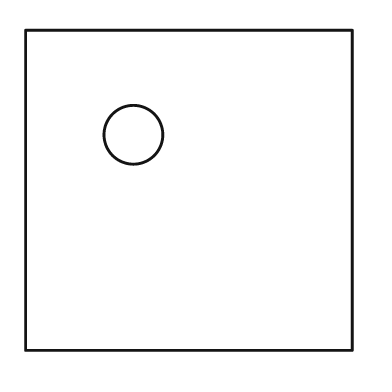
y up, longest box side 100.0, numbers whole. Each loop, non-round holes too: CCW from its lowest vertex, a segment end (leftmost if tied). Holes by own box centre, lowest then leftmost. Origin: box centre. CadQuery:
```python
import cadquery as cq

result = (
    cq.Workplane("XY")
    .moveTo(-50.0, -49.0)
    .lineTo(50.0, -49.0)
    .lineTo(50.0, 49.0)
    .lineTo(-50.0, 49.0)
    .close()
    .moveTo(-17.0, 17.0)
    .circle(9.0)
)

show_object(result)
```